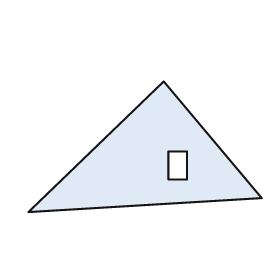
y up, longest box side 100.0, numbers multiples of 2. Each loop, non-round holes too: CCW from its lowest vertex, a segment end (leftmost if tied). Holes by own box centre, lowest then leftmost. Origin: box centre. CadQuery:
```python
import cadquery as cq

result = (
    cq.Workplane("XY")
    .moveTo(-50.0, -28.0)
    .lineTo(50.0, -22.0)
    .lineTo(8.0, 28.0)
    .close()
    .moveTo(10.0, -14.0)
    .lineTo(18.0, -14.0)
    .lineTo(18.0, -2.0)
    .lineTo(10.0, -2.0)
    .close()
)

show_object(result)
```